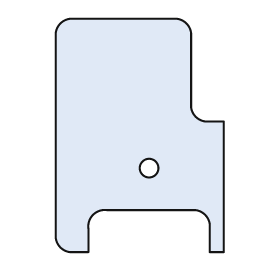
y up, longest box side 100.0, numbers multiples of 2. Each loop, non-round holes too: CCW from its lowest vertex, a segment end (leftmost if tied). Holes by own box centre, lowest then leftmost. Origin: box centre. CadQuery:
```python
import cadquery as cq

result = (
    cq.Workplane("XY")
    .moveTo(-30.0, -50.0)
    .lineTo(-22.0, -50.0)
    .lineTo(-22.0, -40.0)
    .threePointArc((-20.0, -34.0), (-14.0, -32.0))
    .lineTo(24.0, -32.0)
    .threePointArc((28.0, -34.0), (30.0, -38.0))
    .lineTo(30.0, -50.0)
    .lineTo(36.0, -50.0)
    .lineTo(36.0, 6.0)
    .lineTo(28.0, 6.0)
    .threePointArc((24.0, 8.0), (22.0, 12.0))
    .lineTo(22.0, 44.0)
    .threePointArc((20.0, 48.0), (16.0, 50.0))
    .lineTo(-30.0, 50.0)
    .threePointArc((-34.0, 48.0), (-36.0, 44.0))
    .lineTo(-36.0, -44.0)
    .threePointArc((-34.0, -48.0), (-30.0, -50.0))
    .close()
    .moveTo(4.0, -14.0)
    .circle(4.0)
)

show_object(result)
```